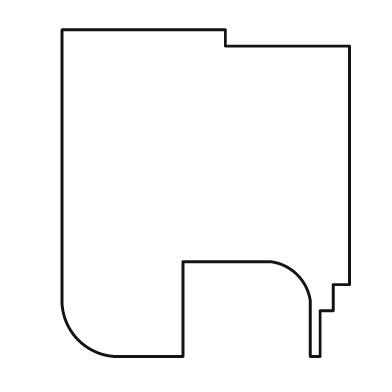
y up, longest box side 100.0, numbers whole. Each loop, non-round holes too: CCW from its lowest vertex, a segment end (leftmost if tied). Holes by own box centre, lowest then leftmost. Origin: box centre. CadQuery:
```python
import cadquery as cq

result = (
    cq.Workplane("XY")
    .moveTo(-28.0, -50.0)
    .lineTo(-7.0, -50.0)
    .lineTo(-7.0, -21.0)
    .lineTo(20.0, -21.0)
    .threePointArc((28.0, -25.0), (32.0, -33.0))
    .lineTo(32.0, -50.0)
    .lineTo(35.0, -50.0)
    .lineTo(35.0, -36.0)
    .lineTo(39.0, -36.0)
    .lineTo(39.0, -28.0)
    .lineTo(44.0, -28.0)
    .lineTo(44.0, 45.0)
    .lineTo(6.0, 45.0)
    .lineTo(6.0, 50.0)
    .lineTo(-44.0, 50.0)
    .lineTo(-44.0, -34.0)
    .threePointArc((-39.0, -45.0), (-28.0, -50.0))
    .close()
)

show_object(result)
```